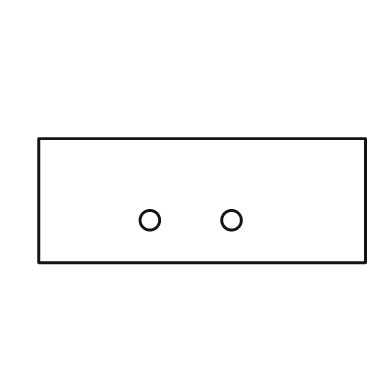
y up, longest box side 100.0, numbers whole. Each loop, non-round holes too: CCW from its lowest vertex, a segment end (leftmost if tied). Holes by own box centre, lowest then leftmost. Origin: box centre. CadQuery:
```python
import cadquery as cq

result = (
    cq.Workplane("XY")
    .moveTo(-50.0, -19.0)
    .lineTo(50.0, -19.0)
    .lineTo(50.0, 19.0)
    .lineTo(-50.0, 19.0)
    .close()
    .moveTo(-16.0, -6.0)
    .circle(3.0)
    .moveTo(9.0, -6.0)
    .circle(3.0)
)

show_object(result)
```